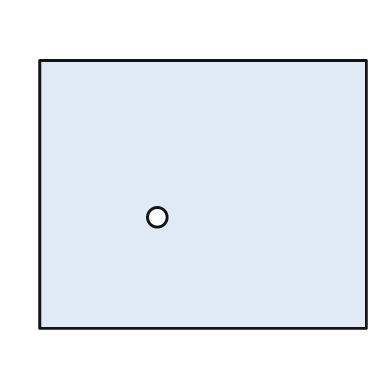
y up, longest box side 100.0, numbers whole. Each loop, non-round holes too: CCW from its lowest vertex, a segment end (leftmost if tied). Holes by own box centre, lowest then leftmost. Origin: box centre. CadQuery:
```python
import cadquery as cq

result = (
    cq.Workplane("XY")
    .moveTo(-50.0, -41.0)
    .lineTo(50.0, -41.0)
    .lineTo(50.0, 41.0)
    .lineTo(-50.0, 41.0)
    .close()
    .moveTo(-14.0, -7.0)
    .circle(3.0)
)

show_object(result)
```